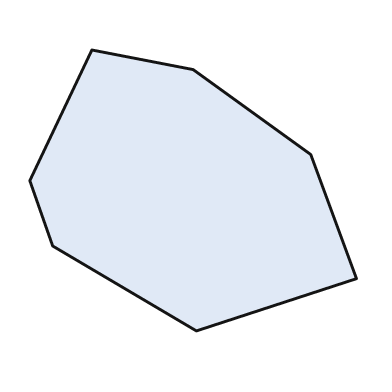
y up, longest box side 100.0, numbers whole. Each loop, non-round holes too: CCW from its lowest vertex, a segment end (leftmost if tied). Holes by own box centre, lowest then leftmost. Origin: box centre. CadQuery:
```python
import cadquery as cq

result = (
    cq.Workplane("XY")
    .moveTo(1.0, -43.0)
    .lineTo(50.0, -27.0)
    .lineTo(36.0, 11.0)
    .lineTo(0.0, 37.0)
    .lineTo(-31.0, 43.0)
    .lineTo(-50.0, 3.0)
    .lineTo(-43.0, -17.0)
    .close()
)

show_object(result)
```